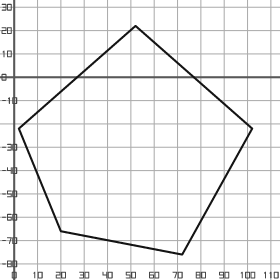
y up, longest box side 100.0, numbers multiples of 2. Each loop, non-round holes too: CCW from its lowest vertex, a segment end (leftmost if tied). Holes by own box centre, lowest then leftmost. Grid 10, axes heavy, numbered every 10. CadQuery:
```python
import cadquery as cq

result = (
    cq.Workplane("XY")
    .moveTo(72.0, -76.0)
    .lineTo(102.0, -22.0)
    .lineTo(52.0, 22.0)
    .lineTo(2.0, -22.0)
    .lineTo(20.0, -66.0)
    .close()
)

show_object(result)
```